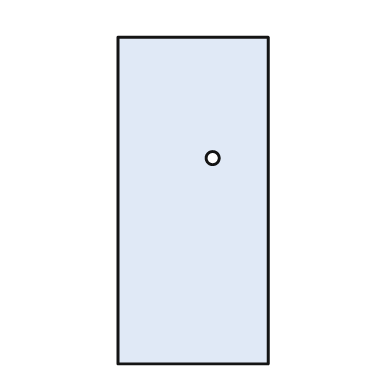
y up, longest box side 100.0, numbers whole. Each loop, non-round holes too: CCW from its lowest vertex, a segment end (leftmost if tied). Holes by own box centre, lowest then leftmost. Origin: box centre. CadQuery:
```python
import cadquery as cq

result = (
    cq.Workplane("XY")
    .moveTo(-23.0, -50.0)
    .lineTo(23.0, -50.0)
    .lineTo(23.0, 50.0)
    .lineTo(-23.0, 50.0)
    .close()
    .moveTo(6.0, 13.0)
    .circle(2.0)
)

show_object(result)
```